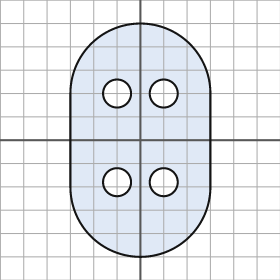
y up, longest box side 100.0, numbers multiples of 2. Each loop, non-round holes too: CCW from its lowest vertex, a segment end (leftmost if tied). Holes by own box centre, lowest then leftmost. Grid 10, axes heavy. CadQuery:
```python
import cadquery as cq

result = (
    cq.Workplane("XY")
    .moveTo(-30.0, -20.0)
    .threePointArc((0.0, -50.0), (30.0, -20.0))
    .lineTo(30.0, 20.0)
    .threePointArc((0.0, 50.0), (-30.0, 20.0))
    .close()
    .moveTo(-10.0, -18.0)
    .circle(6.0)
    .moveTo(10.0, -18.0)
    .circle(6.0)
    .moveTo(-10.0, 20.0)
    .circle(6.0)
    .moveTo(10.0, 20.0)
    .circle(6.0)
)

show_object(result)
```